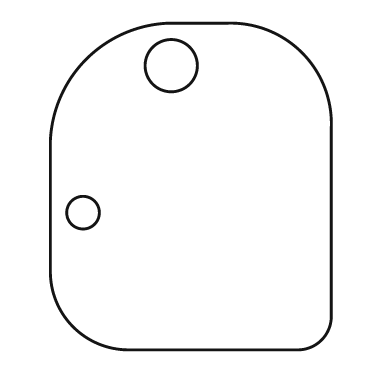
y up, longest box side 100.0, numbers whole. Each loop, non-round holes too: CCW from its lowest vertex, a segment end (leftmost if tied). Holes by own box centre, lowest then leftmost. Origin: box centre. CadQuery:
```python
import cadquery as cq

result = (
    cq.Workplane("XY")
    .moveTo(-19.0, -50.0)
    .lineTo(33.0, -50.0)
    .threePointArc((40.0, -47.0), (43.0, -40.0))
    .lineTo(43.0, 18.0)
    .threePointArc((34.0, 41.0), (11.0, 50.0))
    .lineTo(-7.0, 50.0)
    .threePointArc((-32.0, 39.0), (-43.0, 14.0))
    .lineTo(-43.0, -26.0)
    .threePointArc((-36.0, -43.0), (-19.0, -50.0))
    .close()
    .moveTo(-33.0, -8.0)
    .circle(5.0)
    .moveTo(-6.0, 37.0)
    .circle(8.0)
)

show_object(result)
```